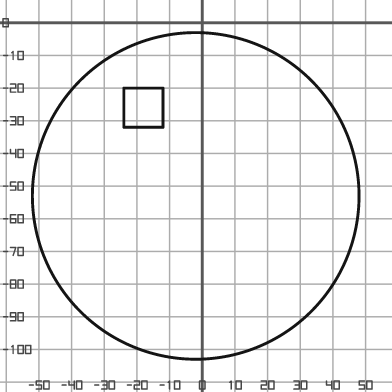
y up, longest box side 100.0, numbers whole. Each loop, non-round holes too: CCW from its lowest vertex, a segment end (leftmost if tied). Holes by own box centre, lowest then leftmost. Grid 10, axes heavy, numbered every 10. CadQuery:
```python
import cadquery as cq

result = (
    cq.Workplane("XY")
    .moveTo(-2.0, -53.0)
    .circle(50.0)
    .moveTo(-24.0, -32.0)
    .lineTo(-12.0, -32.0)
    .lineTo(-12.0, -20.0)
    .lineTo(-24.0, -20.0)
    .close()
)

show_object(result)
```